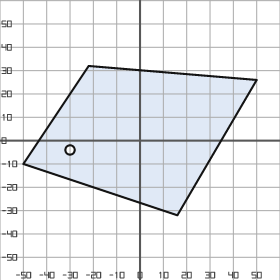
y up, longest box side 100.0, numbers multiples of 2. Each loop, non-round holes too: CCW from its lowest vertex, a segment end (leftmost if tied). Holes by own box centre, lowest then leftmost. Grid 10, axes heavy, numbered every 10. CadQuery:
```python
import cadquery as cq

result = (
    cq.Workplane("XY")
    .moveTo(16.0, -32.0)
    .lineTo(50.0, 26.0)
    .lineTo(-22.0, 32.0)
    .lineTo(-50.0, -10.0)
    .close()
    .moveTo(-30.0, -4.0)
    .circle(2.0)
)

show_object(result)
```